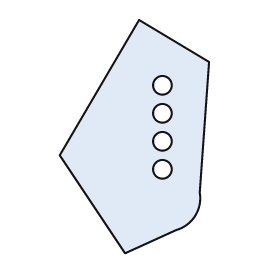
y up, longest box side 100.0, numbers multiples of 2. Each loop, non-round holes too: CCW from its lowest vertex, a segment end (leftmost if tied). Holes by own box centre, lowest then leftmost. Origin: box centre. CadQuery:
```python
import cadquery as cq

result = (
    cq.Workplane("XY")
    .moveTo(-4.0, -50.0)
    .lineTo(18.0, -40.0)
    .threePointArc((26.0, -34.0), (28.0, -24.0))
    .lineTo(32.0, 32.0)
    .lineTo(2.0, 50.0)
    .lineTo(-32.0, -8.0)
    .close()
    .moveTo(12.0, -14.0)
    .circle(4.0)
    .moveTo(12.0, -2.0)
    .circle(4.0)
    .moveTo(12.0, 10.0)
    .circle(4.0)
    .moveTo(12.0, 22.0)
    .circle(4.0)
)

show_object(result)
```